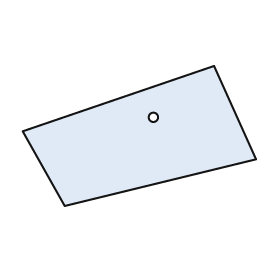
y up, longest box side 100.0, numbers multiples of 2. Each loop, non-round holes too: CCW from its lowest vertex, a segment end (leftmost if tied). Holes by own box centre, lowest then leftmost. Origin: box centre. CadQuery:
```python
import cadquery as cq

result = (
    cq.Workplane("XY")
    .moveTo(-32.0, -30.0)
    .lineTo(50.0, -10.0)
    .lineTo(32.0, 30.0)
    .lineTo(-50.0, 2.0)
    .close()
    .moveTo(6.0, 8.0)
    .circle(2.0)
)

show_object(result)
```